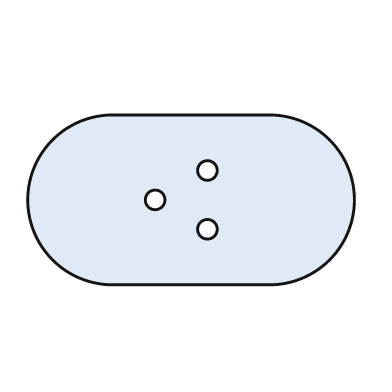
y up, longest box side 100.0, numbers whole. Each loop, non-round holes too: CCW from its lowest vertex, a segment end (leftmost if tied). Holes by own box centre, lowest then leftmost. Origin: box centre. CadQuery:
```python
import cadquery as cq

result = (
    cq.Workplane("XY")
    .moveTo(-24.0, -26.0)
    .lineTo(24.0, -26.0)
    .threePointArc((50.0, 0.0), (24.0, 26.0))
    .lineTo(-24.0, 26.0)
    .threePointArc((-50.0, 0.0), (-24.0, -26.0))
    .close()
    .moveTo(5.0, -9.0)
    .circle(3.0)
    .moveTo(-11.0, 0.0)
    .circle(3.0)
    .moveTo(5.0, 9.0)
    .circle(3.0)
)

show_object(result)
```